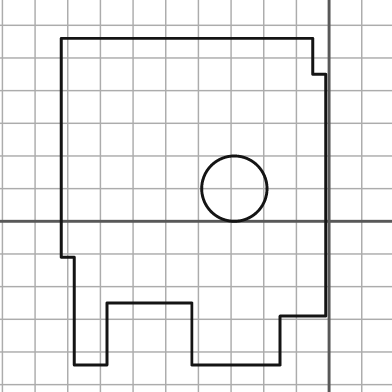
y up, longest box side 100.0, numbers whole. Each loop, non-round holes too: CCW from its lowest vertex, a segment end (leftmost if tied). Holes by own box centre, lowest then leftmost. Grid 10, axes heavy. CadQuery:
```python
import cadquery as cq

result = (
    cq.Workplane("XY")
    .moveTo(-78.0, -44.0)
    .lineTo(-68.0, -44.0)
    .lineTo(-68.0, -25.0)
    .lineTo(-42.0, -25.0)
    .lineTo(-42.0, -44.0)
    .lineTo(-15.0, -44.0)
    .lineTo(-15.0, -29.0)
    .lineTo(-1.0, -29.0)
    .lineTo(-1.0, 45.0)
    .lineTo(-5.0, 45.0)
    .lineTo(-5.0, 56.0)
    .lineTo(-82.0, 56.0)
    .lineTo(-82.0, -11.0)
    .lineTo(-78.0, -11.0)
    .close()
    .moveTo(-29.0, 10.0)
    .circle(10.0)
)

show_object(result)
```